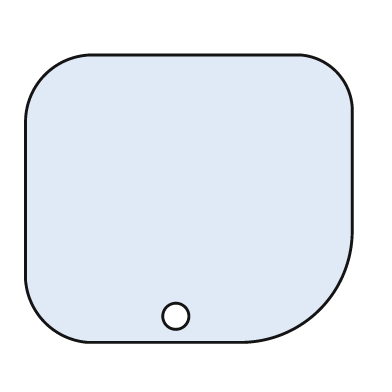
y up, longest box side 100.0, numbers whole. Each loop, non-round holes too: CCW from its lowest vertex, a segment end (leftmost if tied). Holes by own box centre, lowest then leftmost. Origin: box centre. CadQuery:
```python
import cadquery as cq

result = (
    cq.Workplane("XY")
    .moveTo(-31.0, -44.0)
    .lineTo(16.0, -44.0)
    .threePointArc((40.0, -34.0), (50.0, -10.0))
    .lineTo(50.0, 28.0)
    .threePointArc((45.0, 39.0), (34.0, 44.0))
    .lineTo(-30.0, 44.0)
    .threePointArc((-44.0, 38.0), (-50.0, 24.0))
    .lineTo(-50.0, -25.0)
    .threePointArc((-44.0, -38.0), (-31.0, -44.0))
    .close()
    .moveTo(-4.0, -36.0)
    .circle(4.0)
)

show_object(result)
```